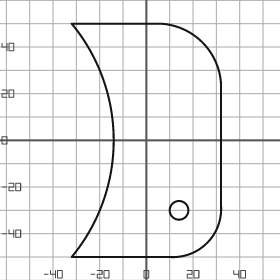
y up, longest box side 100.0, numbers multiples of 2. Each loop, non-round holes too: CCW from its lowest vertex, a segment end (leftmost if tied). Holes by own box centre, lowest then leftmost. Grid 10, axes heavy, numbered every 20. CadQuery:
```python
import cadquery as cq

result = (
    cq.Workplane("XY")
    .moveTo(-32.0, -50.0)
    .lineTo(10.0, -50.0)
    .threePointArc((26.0, -44.0), (32.0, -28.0))
    .lineTo(32.0, 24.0)
    .threePointArc((24.0, 42.0), (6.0, 50.0))
    .lineTo(-32.0, 50.0)
    .threePointArc((-14.0, 0.0), (-32.0, -50.0))
    .close()
    .moveTo(14.0, -30.0)
    .circle(4.0)
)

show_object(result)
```